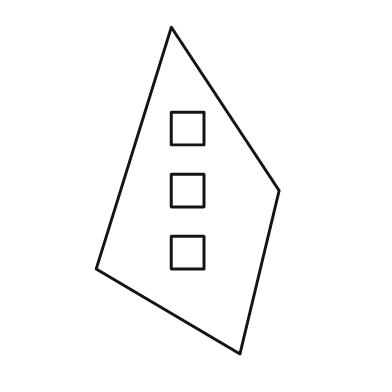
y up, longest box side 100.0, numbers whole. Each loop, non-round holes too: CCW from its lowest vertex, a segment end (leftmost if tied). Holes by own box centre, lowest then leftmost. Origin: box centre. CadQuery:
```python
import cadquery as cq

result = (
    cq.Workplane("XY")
    .moveTo(16.0, -50.0)
    .lineTo(28.0, 0.0)
    .lineTo(-5.0, 50.0)
    .lineTo(-28.0, -24.0)
    .close()
    .moveTo(-5.0, -24.0)
    .lineTo(5.0, -24.0)
    .lineTo(5.0, -14.0)
    .lineTo(-5.0, -14.0)
    .close()
    .moveTo(-5.0, -5.0)
    .lineTo(5.0, -5.0)
    .lineTo(5.0, 5.0)
    .lineTo(-5.0, 5.0)
    .close()
    .moveTo(-5.0, 14.0)
    .lineTo(5.0, 14.0)
    .lineTo(5.0, 24.0)
    .lineTo(-5.0, 24.0)
    .close()
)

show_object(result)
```